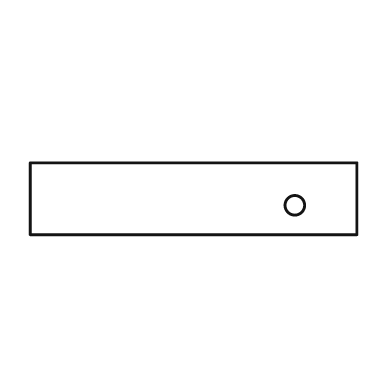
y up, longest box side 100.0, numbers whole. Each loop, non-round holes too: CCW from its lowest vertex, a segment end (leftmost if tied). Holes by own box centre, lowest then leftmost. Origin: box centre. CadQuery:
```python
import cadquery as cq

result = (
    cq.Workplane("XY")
    .moveTo(-50.0, -11.0)
    .lineTo(50.0, -11.0)
    .lineTo(50.0, 11.0)
    .lineTo(-50.0, 11.0)
    .close()
    .moveTo(31.0, -2.0)
    .circle(3.0)
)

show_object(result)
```